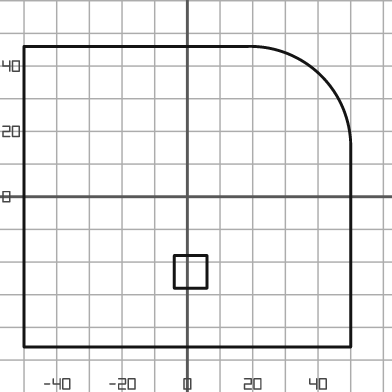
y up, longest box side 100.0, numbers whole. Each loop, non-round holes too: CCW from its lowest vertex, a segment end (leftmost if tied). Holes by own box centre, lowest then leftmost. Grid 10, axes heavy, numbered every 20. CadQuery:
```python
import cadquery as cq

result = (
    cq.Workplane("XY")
    .moveTo(-50.0, -46.0)
    .lineTo(50.0, -46.0)
    .lineTo(50.0, 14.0)
    .threePointArc((41.0, 37.0), (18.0, 46.0))
    .lineTo(-50.0, 46.0)
    .close()
    .moveTo(-4.0, -28.0)
    .lineTo(6.0, -28.0)
    .lineTo(6.0, -18.0)
    .lineTo(-4.0, -18.0)
    .close()
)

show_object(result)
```